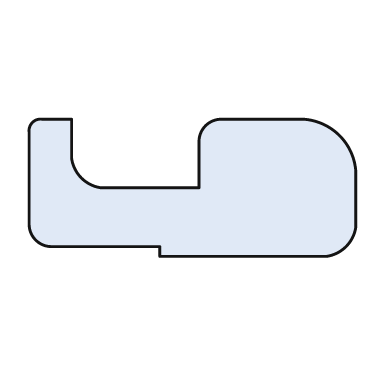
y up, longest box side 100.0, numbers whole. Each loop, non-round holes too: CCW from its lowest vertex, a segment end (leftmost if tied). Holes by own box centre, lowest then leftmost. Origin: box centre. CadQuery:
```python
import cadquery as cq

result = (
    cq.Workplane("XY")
    .moveTo(-10.0, -21.0)
    .lineTo(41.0, -21.0)
    .threePointArc((47.0, -18.0), (50.0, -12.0))
    .lineTo(50.0, 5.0)
    .threePointArc((45.0, 16.0), (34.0, 21.0))
    .lineTo(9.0, 21.0)
    .threePointArc((4.0, 19.0), (2.0, 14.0))
    .lineTo(2.0, 0.0)
    .lineTo(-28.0, 0.0)
    .threePointArc((-34.0, 3.0), (-37.0, 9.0))
    .lineTo(-37.0, 21.0)
    .lineTo(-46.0, 21.0)
    .threePointArc((-49.0, 20.0), (-50.0, 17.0))
    .lineTo(-50.0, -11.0)
    .threePointArc((-48.0, -16.0), (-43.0, -18.0))
    .lineTo(-10.0, -18.0)
    .close()
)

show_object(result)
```